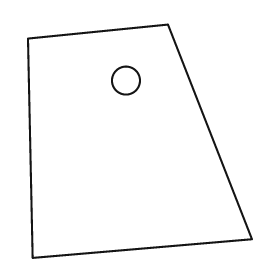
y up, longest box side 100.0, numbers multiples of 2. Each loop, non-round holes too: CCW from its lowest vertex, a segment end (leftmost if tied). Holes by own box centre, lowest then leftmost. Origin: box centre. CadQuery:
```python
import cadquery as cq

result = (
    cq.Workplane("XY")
    .moveTo(-46.0, -50.0)
    .lineTo(48.0, -42.0)
    .lineTo(12.0, 50.0)
    .lineTo(-48.0, 44.0)
    .close()
    .moveTo(-6.0, 26.0)
    .circle(6.0)
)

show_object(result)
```